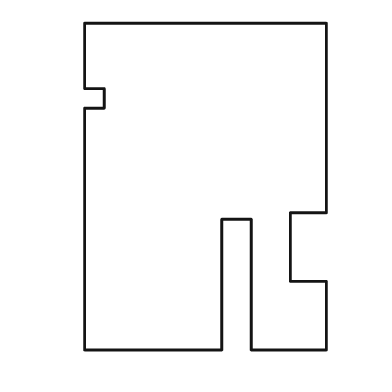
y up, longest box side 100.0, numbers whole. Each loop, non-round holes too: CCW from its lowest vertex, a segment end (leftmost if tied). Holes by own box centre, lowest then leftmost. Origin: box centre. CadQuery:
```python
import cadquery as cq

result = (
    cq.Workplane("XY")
    .moveTo(-37.0, -50.0)
    .lineTo(5.0, -50.0)
    .lineTo(5.0, -10.0)
    .lineTo(14.0, -10.0)
    .lineTo(14.0, -50.0)
    .lineTo(37.0, -50.0)
    .lineTo(37.0, -29.0)
    .lineTo(26.0, -29.0)
    .lineTo(26.0, -8.0)
    .lineTo(37.0, -8.0)
    .lineTo(37.0, 50.0)
    .lineTo(-37.0, 50.0)
    .lineTo(-37.0, 30.0)
    .lineTo(-31.0, 30.0)
    .lineTo(-31.0, 24.0)
    .lineTo(-37.0, 24.0)
    .close()
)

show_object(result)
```